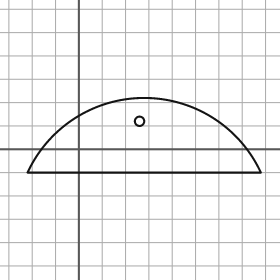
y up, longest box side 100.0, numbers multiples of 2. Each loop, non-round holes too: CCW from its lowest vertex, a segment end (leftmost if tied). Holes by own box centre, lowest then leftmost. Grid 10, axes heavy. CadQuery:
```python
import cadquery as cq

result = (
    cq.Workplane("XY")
    .moveTo(-22.0, -10.0)
    .lineTo(78.0, -10.0)
    .threePointArc((28.0, 22.0), (-22.0, -10.0))
    .close()
    .moveTo(26.0, 12.0)
    .circle(2.0)
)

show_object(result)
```